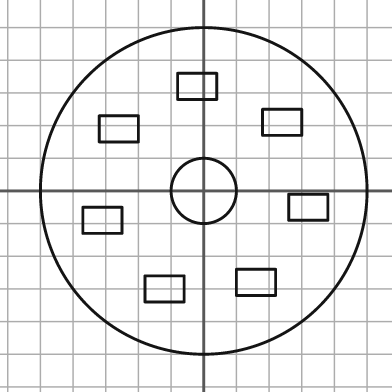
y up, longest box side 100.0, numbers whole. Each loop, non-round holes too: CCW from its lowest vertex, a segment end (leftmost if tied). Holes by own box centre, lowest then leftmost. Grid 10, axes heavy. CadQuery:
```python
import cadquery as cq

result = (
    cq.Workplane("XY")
    .moveTo(0.0, 0.0)
    .circle(50.0)
    .moveTo(-18.0, -34.0)
    .lineTo(-6.0, -34.0)
    .lineTo(-6.0, -26.0)
    .lineTo(-18.0, -26.0)
    .close()
    .moveTo(10.0, -32.0)
    .lineTo(22.0, -32.0)
    .lineTo(22.0, -24.0)
    .lineTo(10.0, -24.0)
    .close()
    .moveTo(-37.0, -13.0)
    .lineTo(-25.0, -13.0)
    .lineTo(-25.0, -5.0)
    .lineTo(-37.0, -5.0)
    .close()
    .moveTo(26.0, -9.0)
    .lineTo(38.0, -9.0)
    .lineTo(38.0, -1.0)
    .lineTo(26.0, -1.0)
    .close()
    .moveTo(0.0, 0.0)
    .circle(10.0)
    .moveTo(-32.0, 15.0)
    .lineTo(-20.0, 15.0)
    .lineTo(-20.0, 23.0)
    .lineTo(-32.0, 23.0)
    .close()
    .moveTo(18.0, 17.0)
    .lineTo(30.0, 17.0)
    .lineTo(30.0, 25.0)
    .lineTo(18.0, 25.0)
    .close()
    .moveTo(-8.0, 28.0)
    .lineTo(4.0, 28.0)
    .lineTo(4.0, 36.0)
    .lineTo(-8.0, 36.0)
    .close()
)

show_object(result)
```